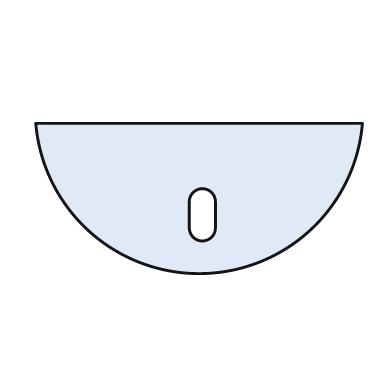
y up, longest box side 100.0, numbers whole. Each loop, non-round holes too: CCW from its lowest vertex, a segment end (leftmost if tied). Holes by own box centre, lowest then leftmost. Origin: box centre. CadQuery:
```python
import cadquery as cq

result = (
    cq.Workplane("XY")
    .moveTo(-50.0, 23.0)
    .threePointArc((0.0, -23.0), (50.0, 23.0))
    .close()
    .moveTo(-3.0, -9.0)
    .threePointArc((1.0, -13.0), (5.0, -9.0))
    .lineTo(5.0, -1.0)
    .threePointArc((1.0, 3.0), (-3.0, -1.0))
    .close()
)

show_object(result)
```